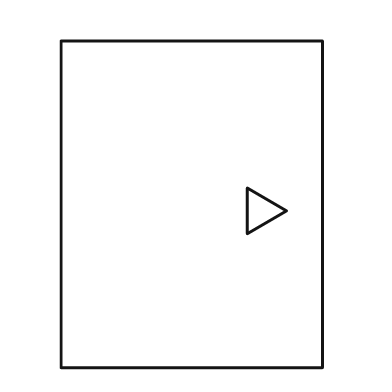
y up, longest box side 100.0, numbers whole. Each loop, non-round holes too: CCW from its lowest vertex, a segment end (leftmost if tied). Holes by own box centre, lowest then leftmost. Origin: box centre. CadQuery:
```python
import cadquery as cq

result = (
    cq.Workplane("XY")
    .moveTo(-40.0, -50.0)
    .lineTo(40.0, -50.0)
    .lineTo(40.0, 50.0)
    .lineTo(-40.0, 50.0)
    .close()
    .moveTo(17.0, -9.0)
    .lineTo(29.0, -2.0)
    .lineTo(17.0, 5.0)
    .close()
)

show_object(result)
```